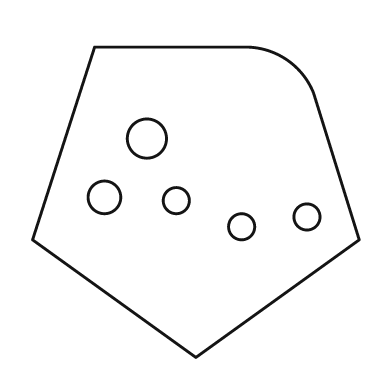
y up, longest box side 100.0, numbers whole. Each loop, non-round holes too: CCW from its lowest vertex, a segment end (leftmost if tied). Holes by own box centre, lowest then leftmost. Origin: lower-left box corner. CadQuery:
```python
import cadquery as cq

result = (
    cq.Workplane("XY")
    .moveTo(50.0, 0.0)
    .lineTo(100.0, 36.0)
    .lineTo(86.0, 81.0)
    .threePointArc((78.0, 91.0), (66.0, 95.0))
    .lineTo(19.0, 95.0)
    .lineTo(0.0, 36.0)
    .close()
    .moveTo(64.0, 40.0)
    .circle(4.0)
    .moveTo(84.0, 43.0)
    .circle(4.0)
    .moveTo(44.0, 48.0)
    .circle(4.0)
    .moveTo(22.0, 49.0)
    .circle(5.0)
    .moveTo(35.0, 67.0)
    .circle(6.0)
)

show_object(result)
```